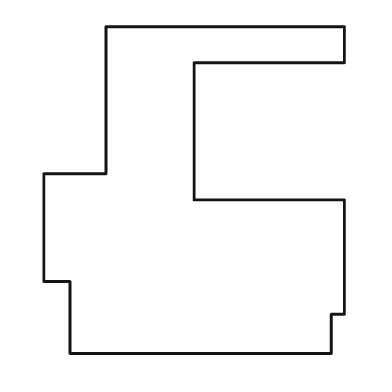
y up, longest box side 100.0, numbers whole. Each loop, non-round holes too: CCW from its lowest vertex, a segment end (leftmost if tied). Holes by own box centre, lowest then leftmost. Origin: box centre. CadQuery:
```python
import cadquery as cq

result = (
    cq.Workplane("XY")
    .moveTo(-38.0, -50.0)
    .lineTo(42.0, -50.0)
    .lineTo(42.0, -38.0)
    .lineTo(46.0, -38.0)
    .lineTo(46.0, -3.0)
    .lineTo(0.0, -3.0)
    .lineTo(0.0, 39.0)
    .lineTo(46.0, 39.0)
    .lineTo(46.0, 50.0)
    .lineTo(-27.0, 50.0)
    .lineTo(-27.0, 5.0)
    .lineTo(-46.0, 5.0)
    .lineTo(-46.0, -28.0)
    .lineTo(-38.0, -28.0)
    .close()
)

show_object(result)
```